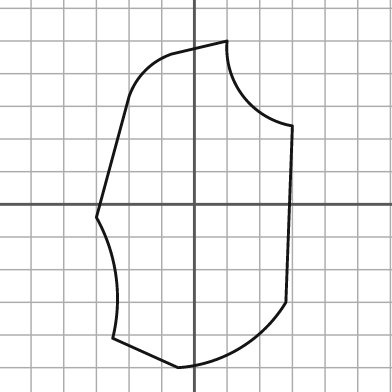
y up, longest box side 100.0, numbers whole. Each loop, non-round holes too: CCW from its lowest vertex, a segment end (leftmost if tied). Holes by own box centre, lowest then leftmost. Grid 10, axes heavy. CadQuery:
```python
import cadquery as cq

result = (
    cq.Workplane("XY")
    .moveTo(-5.0, -50.0)
    .threePointArc((14.0, -44.0), (28.0, -30.0))
    .lineTo(30.0, 24.0)
    .threePointArc((15.0, 33.0), (10.0, 50.0))
    .lineTo(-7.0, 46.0)
    .threePointArc((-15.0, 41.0), (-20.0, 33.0))
    .lineTo(-30.0, -4.0)
    .threePointArc((-24.0, -22.0), (-25.0, -41.0))
    .close()
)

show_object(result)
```